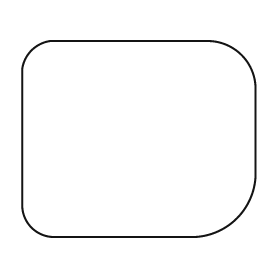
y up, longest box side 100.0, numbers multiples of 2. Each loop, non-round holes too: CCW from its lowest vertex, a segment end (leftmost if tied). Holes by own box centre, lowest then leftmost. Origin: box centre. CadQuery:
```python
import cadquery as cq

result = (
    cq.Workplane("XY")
    .moveTo(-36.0, -42.0)
    .lineTo(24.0, -42.0)
    .threePointArc((42.0, -34.0), (50.0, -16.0))
    .lineTo(50.0, 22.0)
    .threePointArc((44.0, 36.0), (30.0, 42.0))
    .lineTo(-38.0, 42.0)
    .threePointArc((-46.0, 38.0), (-50.0, 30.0))
    .lineTo(-50.0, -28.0)
    .threePointArc((-46.0, -38.0), (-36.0, -42.0))
    .close()
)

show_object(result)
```